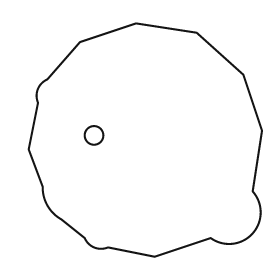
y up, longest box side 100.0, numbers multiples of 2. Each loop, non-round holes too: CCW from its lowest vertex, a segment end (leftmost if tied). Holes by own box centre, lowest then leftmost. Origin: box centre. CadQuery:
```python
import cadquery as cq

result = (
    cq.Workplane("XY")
    .moveTo(4.0, -50.0)
    .lineTo(28.0, -42.0)
    .threePointArc((46.0, -40.0), (46.0, -22.0))
    .lineTo(50.0, 4.0)
    .lineTo(42.0, 28.0)
    .lineTo(22.0, 46.0)
    .lineTo(-4.0, 50.0)
    .lineTo(-28.0, 42.0)
    .lineTo(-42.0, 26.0)
    .threePointArc((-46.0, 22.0), (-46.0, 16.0))
    .lineTo(-50.0, -4.0)
    .lineTo(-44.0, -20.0)
    .threePointArc((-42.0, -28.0), (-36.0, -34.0))
    .lineTo(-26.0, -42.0)
    .threePointArc((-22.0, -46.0), (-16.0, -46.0))
    .close()
    .moveTo(-22.0, 2.0)
    .circle(4.0)
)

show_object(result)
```